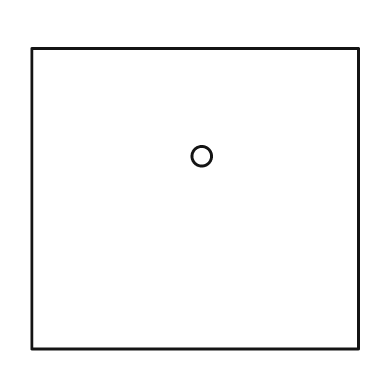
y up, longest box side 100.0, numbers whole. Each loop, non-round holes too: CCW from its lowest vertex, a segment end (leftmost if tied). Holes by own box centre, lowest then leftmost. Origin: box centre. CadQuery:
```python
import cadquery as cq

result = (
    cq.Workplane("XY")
    .moveTo(-50.0, -46.0)
    .lineTo(50.0, -46.0)
    .lineTo(50.0, 46.0)
    .lineTo(-50.0, 46.0)
    .close()
    .moveTo(2.0, 13.0)
    .circle(3.0)
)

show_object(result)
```